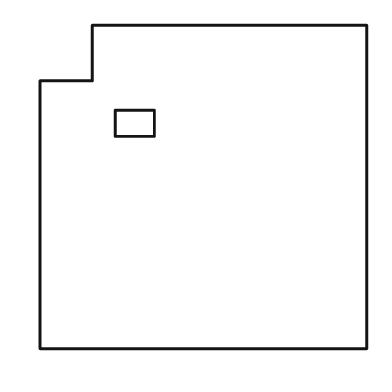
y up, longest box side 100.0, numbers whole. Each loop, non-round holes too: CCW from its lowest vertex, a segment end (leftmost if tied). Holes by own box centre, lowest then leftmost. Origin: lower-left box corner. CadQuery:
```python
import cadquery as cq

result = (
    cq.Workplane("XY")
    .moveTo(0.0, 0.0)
    .lineTo(100.0, 0.0)
    .lineTo(100.0, 99.0)
    .lineTo(16.0, 99.0)
    .lineTo(16.0, 82.0)
    .lineTo(0.0, 82.0)
    .close()
    .moveTo(23.0, 65.0)
    .lineTo(35.0, 65.0)
    .lineTo(35.0, 73.0)
    .lineTo(23.0, 73.0)
    .close()
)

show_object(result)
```